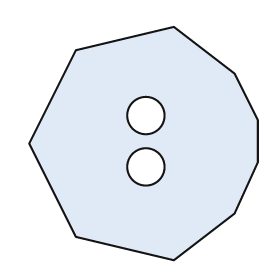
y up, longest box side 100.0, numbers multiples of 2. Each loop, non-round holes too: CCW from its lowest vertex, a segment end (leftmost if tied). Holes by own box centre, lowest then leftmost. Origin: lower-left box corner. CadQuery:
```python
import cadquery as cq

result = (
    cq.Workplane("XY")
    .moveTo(62.0, 0.0)
    .lineTo(88.0, 20.0)
    .lineTo(98.0, 42.0)
    .lineTo(98.0, 60.0)
    .lineTo(88.0, 80.0)
    .lineTo(62.0, 100.0)
    .lineTo(20.0, 90.0)
    .lineTo(0.0, 50.0)
    .lineTo(20.0, 10.0)
    .close()
    .moveTo(50.0, 40.0)
    .circle(8.0)
    .moveTo(50.0, 62.0)
    .circle(8.0)
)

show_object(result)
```